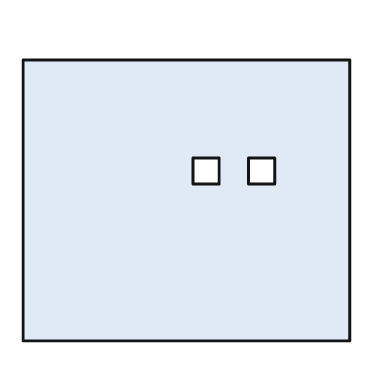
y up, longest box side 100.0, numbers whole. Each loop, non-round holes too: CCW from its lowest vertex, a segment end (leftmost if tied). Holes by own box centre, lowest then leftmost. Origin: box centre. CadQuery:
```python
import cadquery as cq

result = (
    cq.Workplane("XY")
    .moveTo(-50.0, -43.0)
    .lineTo(50.0, -43.0)
    .lineTo(50.0, 43.0)
    .lineTo(-50.0, 43.0)
    .close()
    .moveTo(2.0, 5.0)
    .lineTo(10.0, 5.0)
    .lineTo(10.0, 13.0)
    .lineTo(2.0, 13.0)
    .close()
    .moveTo(19.0, 5.0)
    .lineTo(27.0, 5.0)
    .lineTo(27.0, 13.0)
    .lineTo(19.0, 13.0)
    .close()
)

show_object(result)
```